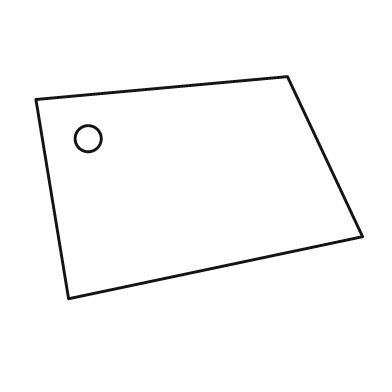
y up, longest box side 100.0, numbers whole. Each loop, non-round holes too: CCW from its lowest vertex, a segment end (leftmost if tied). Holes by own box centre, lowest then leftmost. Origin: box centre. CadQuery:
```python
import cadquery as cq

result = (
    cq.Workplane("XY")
    .moveTo(-40.0, -34.0)
    .lineTo(50.0, -15.0)
    .lineTo(27.0, 34.0)
    .lineTo(-50.0, 27.0)
    .close()
    .moveTo(-34.0, 15.0)
    .circle(4.0)
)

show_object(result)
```